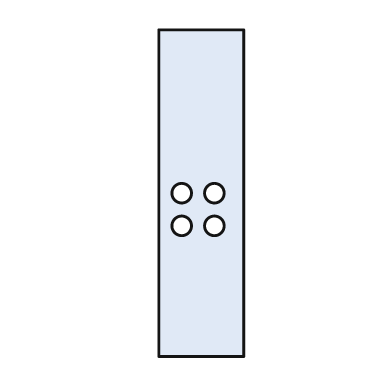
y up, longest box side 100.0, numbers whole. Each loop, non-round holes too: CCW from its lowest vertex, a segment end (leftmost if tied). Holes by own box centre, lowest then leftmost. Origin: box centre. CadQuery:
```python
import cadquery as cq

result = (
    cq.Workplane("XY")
    .moveTo(-13.0, -50.0)
    .lineTo(13.0, -50.0)
    .lineTo(13.0, 50.0)
    .lineTo(-13.0, 50.0)
    .close()
    .moveTo(-6.0, -10.0)
    .circle(3.0)
    .moveTo(4.0, -10.0)
    .circle(3.0)
    .moveTo(-6.0, 0.0)
    .circle(3.0)
    .moveTo(4.0, 0.0)
    .circle(3.0)
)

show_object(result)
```